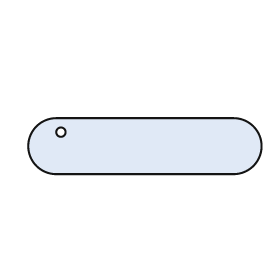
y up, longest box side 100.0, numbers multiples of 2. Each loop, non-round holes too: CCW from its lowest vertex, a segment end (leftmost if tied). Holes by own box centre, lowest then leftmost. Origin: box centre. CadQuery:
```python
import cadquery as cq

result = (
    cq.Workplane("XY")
    .moveTo(-38.0, -12.0)
    .lineTo(38.0, -12.0)
    .threePointArc((50.0, 0.0), (38.0, 12.0))
    .lineTo(-38.0, 12.0)
    .threePointArc((-50.0, 0.0), (-38.0, -12.0))
    .close()
    .moveTo(-36.0, 6.0)
    .circle(2.0)
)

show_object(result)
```